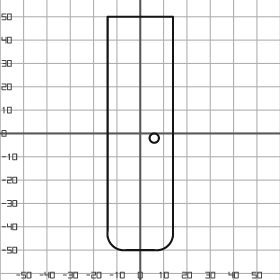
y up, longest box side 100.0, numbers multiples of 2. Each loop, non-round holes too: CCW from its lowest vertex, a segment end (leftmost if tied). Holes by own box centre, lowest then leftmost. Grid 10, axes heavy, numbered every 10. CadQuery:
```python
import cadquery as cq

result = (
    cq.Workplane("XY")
    .moveTo(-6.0, -50.0)
    .lineTo(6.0, -50.0)
    .threePointArc((12.0, -48.0), (14.0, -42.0))
    .lineTo(14.0, 50.0)
    .lineTo(-14.0, 50.0)
    .lineTo(-14.0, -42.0)
    .threePointArc((-12.0, -48.0), (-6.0, -50.0))
    .close()
    .moveTo(6.0, -2.0)
    .circle(2.0)
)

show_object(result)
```